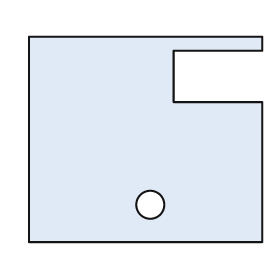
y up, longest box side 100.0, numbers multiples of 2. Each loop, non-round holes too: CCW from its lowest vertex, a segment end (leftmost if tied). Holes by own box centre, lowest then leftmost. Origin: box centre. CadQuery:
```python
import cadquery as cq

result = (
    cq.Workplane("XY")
    .moveTo(-50.0, -44.0)
    .lineTo(50.0, -44.0)
    .lineTo(50.0, 16.0)
    .lineTo(12.0, 16.0)
    .lineTo(12.0, 38.0)
    .lineTo(50.0, 38.0)
    .lineTo(50.0, 44.0)
    .lineTo(-50.0, 44.0)
    .close()
    .moveTo(2.0, -28.0)
    .circle(6.0)
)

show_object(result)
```